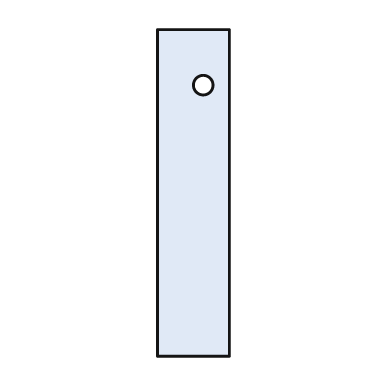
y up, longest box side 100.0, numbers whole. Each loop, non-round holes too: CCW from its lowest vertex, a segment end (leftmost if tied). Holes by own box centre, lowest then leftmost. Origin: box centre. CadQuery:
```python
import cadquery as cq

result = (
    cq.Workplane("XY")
    .moveTo(-11.0, -50.0)
    .lineTo(11.0, -50.0)
    .lineTo(11.0, 50.0)
    .lineTo(-11.0, 50.0)
    .close()
    .moveTo(3.0, 33.0)
    .circle(3.0)
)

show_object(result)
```